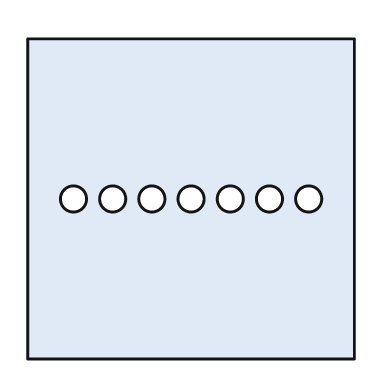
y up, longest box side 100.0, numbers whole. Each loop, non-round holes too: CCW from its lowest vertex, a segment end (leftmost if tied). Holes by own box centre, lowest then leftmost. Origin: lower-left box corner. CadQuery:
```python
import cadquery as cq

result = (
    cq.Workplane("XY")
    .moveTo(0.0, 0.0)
    .lineTo(100.0, 0.0)
    .lineTo(100.0, 98.0)
    .lineTo(0.0, 98.0)
    .close()
    .moveTo(14.0, 49.0)
    .circle(4.0)
    .moveTo(26.0, 49.0)
    .circle(4.0)
    .moveTo(38.0, 49.0)
    .circle(4.0)
    .moveTo(50.0, 49.0)
    .circle(4.0)
    .moveTo(62.0, 49.0)
    .circle(4.0)
    .moveTo(74.0, 49.0)
    .circle(4.0)
    .moveTo(86.0, 49.0)
    .circle(4.0)
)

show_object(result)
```